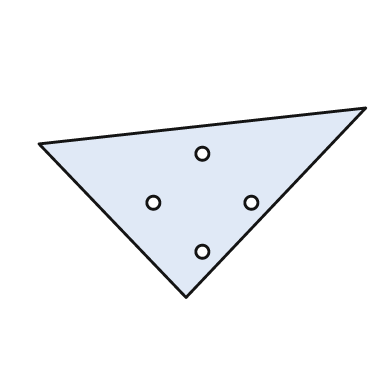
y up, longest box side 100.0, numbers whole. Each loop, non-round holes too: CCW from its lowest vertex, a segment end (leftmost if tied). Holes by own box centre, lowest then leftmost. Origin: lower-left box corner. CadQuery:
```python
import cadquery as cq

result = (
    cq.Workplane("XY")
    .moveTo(45.0, 0.0)
    .lineTo(100.0, 58.0)
    .lineTo(0.0, 47.0)
    .close()
    .moveTo(50.0, 14.0)
    .circle(2.0)
    .moveTo(35.0, 29.0)
    .circle(2.0)
    .moveTo(65.0, 29.0)
    .circle(2.0)
    .moveTo(50.0, 44.0)
    .circle(2.0)
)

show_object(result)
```